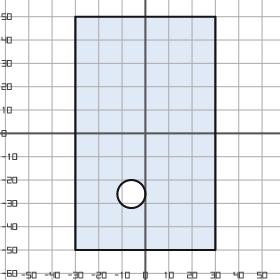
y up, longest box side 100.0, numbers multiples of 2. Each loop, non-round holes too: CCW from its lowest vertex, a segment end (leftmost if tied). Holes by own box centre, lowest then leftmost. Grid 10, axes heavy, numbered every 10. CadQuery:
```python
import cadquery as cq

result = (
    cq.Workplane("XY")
    .moveTo(-30.0, -50.0)
    .lineTo(30.0, -50.0)
    .lineTo(30.0, 50.0)
    .lineTo(-30.0, 50.0)
    .close()
    .moveTo(-6.0, -26.0)
    .circle(6.0)
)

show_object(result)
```